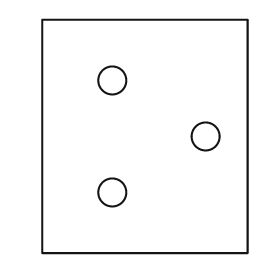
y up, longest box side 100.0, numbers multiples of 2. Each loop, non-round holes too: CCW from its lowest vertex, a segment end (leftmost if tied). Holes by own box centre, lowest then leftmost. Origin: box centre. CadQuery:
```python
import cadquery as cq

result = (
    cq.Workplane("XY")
    .moveTo(-44.0, -50.0)
    .lineTo(44.0, -50.0)
    .lineTo(44.0, 50.0)
    .lineTo(-44.0, 50.0)
    .close()
    .moveTo(-14.0, -24.0)
    .circle(6.0)
    .moveTo(26.0, 0.0)
    .circle(6.0)
    .moveTo(-14.0, 24.0)
    .circle(6.0)
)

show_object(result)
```